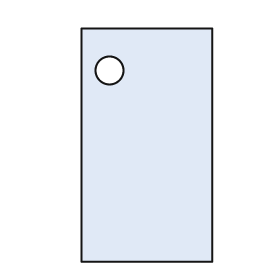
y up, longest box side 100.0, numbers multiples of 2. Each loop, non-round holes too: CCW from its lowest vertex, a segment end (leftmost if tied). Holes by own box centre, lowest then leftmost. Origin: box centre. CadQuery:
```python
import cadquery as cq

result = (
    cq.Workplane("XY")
    .moveTo(-28.0, -50.0)
    .lineTo(28.0, -50.0)
    .lineTo(28.0, 50.0)
    .lineTo(-28.0, 50.0)
    .close()
    .moveTo(-16.0, 32.0)
    .circle(6.0)
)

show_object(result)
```